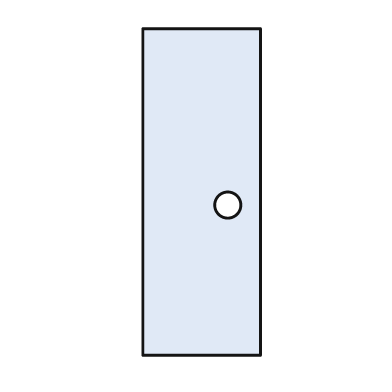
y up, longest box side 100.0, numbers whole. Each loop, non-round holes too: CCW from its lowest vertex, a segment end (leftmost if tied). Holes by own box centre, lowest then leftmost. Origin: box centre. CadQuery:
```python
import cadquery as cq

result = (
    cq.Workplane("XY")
    .moveTo(-18.0, -50.0)
    .lineTo(18.0, -50.0)
    .lineTo(18.0, 50.0)
    .lineTo(-18.0, 50.0)
    .close()
    .moveTo(8.0, -4.0)
    .circle(4.0)
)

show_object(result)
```